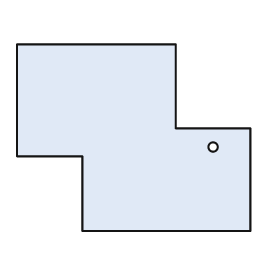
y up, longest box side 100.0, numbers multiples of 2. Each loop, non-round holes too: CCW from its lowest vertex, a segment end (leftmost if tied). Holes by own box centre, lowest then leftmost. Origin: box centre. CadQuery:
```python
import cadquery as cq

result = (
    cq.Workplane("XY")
    .moveTo(-22.0, -40.0)
    .lineTo(50.0, -40.0)
    .lineTo(50.0, 4.0)
    .lineTo(18.0, 4.0)
    .lineTo(18.0, 40.0)
    .lineTo(-50.0, 40.0)
    .lineTo(-50.0, -8.0)
    .lineTo(-22.0, -8.0)
    .close()
    .moveTo(34.0, -4.0)
    .circle(2.0)
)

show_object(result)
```